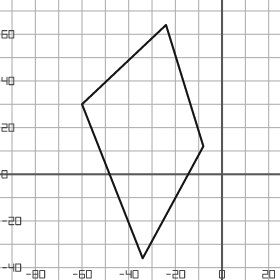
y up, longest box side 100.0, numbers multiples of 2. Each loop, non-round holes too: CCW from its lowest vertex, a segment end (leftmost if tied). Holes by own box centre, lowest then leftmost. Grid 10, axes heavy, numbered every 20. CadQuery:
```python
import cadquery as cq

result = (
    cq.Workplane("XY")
    .moveTo(-34.0, -36.0)
    .lineTo(-8.0, 12.0)
    .lineTo(-24.0, 64.0)
    .lineTo(-60.0, 30.0)
    .close()
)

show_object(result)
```